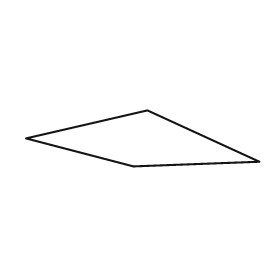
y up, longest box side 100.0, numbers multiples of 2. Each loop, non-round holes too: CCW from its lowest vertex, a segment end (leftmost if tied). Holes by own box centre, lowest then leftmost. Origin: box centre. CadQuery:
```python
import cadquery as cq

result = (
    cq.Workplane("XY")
    .moveTo(-4.0, -12.0)
    .lineTo(50.0, -10.0)
    .lineTo(2.0, 12.0)
    .lineTo(-50.0, 0.0)
    .close()
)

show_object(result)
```